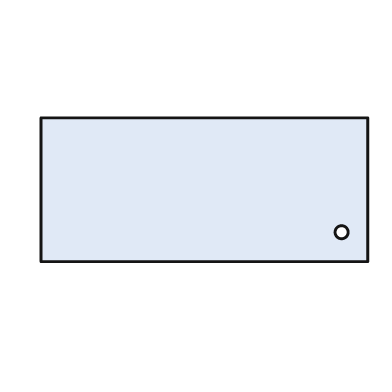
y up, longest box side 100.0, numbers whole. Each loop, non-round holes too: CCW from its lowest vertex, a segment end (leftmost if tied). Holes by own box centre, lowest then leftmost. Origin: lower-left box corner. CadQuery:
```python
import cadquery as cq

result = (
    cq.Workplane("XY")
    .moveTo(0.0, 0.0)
    .lineTo(100.0, 0.0)
    .lineTo(100.0, 44.0)
    .lineTo(0.0, 44.0)
    .close()
    .moveTo(92.0, 9.0)
    .circle(2.0)
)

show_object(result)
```